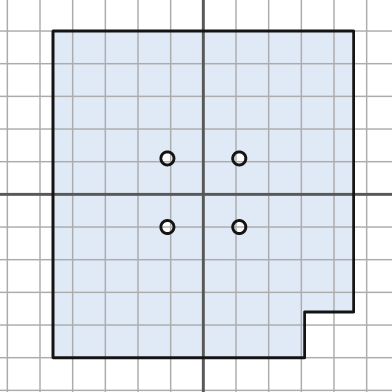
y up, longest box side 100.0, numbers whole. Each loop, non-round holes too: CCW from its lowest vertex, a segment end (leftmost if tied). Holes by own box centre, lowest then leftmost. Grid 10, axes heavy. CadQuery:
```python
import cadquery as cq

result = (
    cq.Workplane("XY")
    .moveTo(-46.0, -50.0)
    .lineTo(31.0, -50.0)
    .lineTo(31.0, -36.0)
    .lineTo(46.0, -36.0)
    .lineTo(46.0, 50.0)
    .lineTo(-46.0, 50.0)
    .close()
    .moveTo(-11.0, -10.0)
    .circle(2.0)
    .moveTo(11.0, -10.0)
    .circle(2.0)
    .moveTo(-11.0, 11.0)
    .circle(2.0)
    .moveTo(11.0, 11.0)
    .circle(2.0)
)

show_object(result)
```